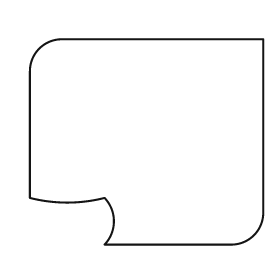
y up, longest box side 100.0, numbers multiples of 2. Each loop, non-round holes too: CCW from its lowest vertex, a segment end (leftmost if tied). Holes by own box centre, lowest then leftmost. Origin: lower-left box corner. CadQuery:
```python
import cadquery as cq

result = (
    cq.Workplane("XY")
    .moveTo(32.0, 0.0)
    .lineTo(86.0, 0.0)
    .threePointArc((96.0, 4.0), (100.0, 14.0))
    .lineTo(100.0, 88.0)
    .lineTo(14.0, 88.0)
    .threePointArc((4.0, 84.0), (0.0, 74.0))
    .lineTo(0.0, 20.0)
    .threePointArc((16.0, 18.0), (32.0, 20.0))
    .threePointArc((36.0, 10.0), (32.0, 0.0))
    .close()
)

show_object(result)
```